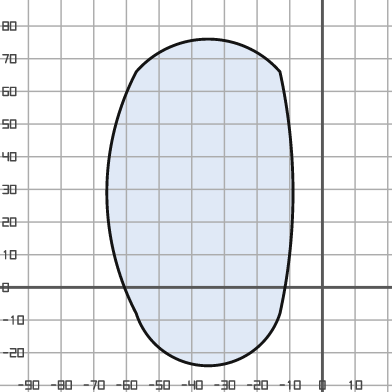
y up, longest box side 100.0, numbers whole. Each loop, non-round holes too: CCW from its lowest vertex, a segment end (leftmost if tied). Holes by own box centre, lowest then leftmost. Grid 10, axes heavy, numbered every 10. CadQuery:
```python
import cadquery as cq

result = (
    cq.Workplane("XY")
    .moveTo(-57.0, -8.0)
    .threePointArc((-35.0, -24.0), (-13.0, -8.0))
    .threePointArc((-9.0, 29.0), (-13.0, 66.0))
    .threePointArc((-35.0, 76.0), (-57.0, 66.0))
    .threePointArc((-66.0, 29.0), (-57.0, -8.0))
    .close()
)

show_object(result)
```